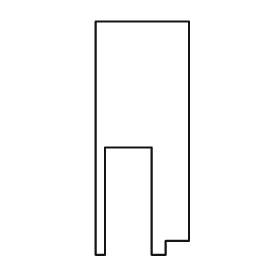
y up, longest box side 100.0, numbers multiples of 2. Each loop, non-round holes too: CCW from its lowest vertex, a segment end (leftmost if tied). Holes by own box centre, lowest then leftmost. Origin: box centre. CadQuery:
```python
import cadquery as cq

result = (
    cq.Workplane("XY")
    .moveTo(-20.0, -50.0)
    .lineTo(-16.0, -50.0)
    .lineTo(-16.0, -4.0)
    .lineTo(4.0, -4.0)
    .lineTo(4.0, -50.0)
    .lineTo(10.0, -50.0)
    .lineTo(10.0, -44.0)
    .lineTo(20.0, -44.0)
    .lineTo(20.0, 50.0)
    .lineTo(-20.0, 50.0)
    .close()
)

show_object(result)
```